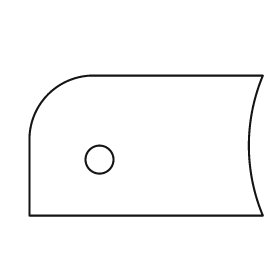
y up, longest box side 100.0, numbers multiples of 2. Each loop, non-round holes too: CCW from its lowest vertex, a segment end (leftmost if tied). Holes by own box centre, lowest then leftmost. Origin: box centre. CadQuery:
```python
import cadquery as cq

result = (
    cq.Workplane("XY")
    .moveTo(-50.0, -30.0)
    .lineTo(50.0, -30.0)
    .threePointArc((44.0, 0.0), (50.0, 30.0))
    .lineTo(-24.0, 30.0)
    .threePointArc((-42.0, 22.0), (-50.0, 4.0))
    .close()
    .moveTo(-20.0, -6.0)
    .circle(6.0)
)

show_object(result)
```